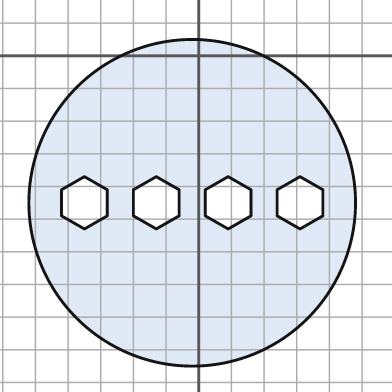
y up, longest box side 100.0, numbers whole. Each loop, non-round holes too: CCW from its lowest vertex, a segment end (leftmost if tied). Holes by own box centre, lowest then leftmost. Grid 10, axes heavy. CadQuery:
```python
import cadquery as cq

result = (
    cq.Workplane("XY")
    .moveTo(-2.0, -45.0)
    .circle(50.0)
    .moveTo(-35.0, -53.0)
    .lineTo(-28.0, -49.0)
    .lineTo(-28.0, -41.0)
    .lineTo(-35.0, -37.0)
    .lineTo(-42.0, -41.0)
    .lineTo(-42.0, -49.0)
    .close()
    .moveTo(-13.0, -53.0)
    .lineTo(-6.0, -49.0)
    .lineTo(-6.0, -41.0)
    .lineTo(-13.0, -37.0)
    .lineTo(-20.0, -41.0)
    .lineTo(-20.0, -49.0)
    .close()
    .moveTo(9.0, -53.0)
    .lineTo(16.0, -49.0)
    .lineTo(16.0, -41.0)
    .lineTo(9.0, -37.0)
    .lineTo(2.0, -41.0)
    .lineTo(2.0, -49.0)
    .close()
    .moveTo(31.0, -53.0)
    .lineTo(38.0, -49.0)
    .lineTo(38.0, -41.0)
    .lineTo(31.0, -37.0)
    .lineTo(24.0, -41.0)
    .lineTo(24.0, -49.0)
    .close()
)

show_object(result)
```